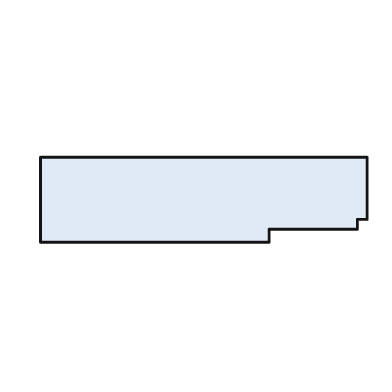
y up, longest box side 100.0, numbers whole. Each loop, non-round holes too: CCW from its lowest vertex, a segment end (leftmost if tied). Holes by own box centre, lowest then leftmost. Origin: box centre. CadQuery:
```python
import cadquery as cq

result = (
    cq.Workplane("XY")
    .moveTo(-50.0, -13.0)
    .lineTo(20.0, -13.0)
    .lineTo(20.0, -9.0)
    .lineTo(47.0, -9.0)
    .lineTo(47.0, -6.0)
    .lineTo(50.0, -6.0)
    .lineTo(50.0, 13.0)
    .lineTo(-50.0, 13.0)
    .close()
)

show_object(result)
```